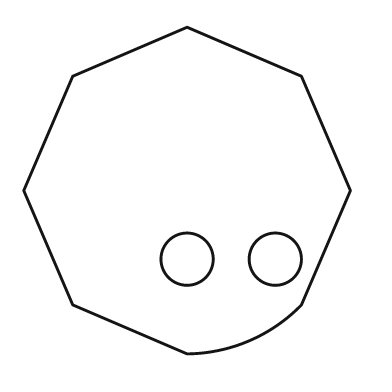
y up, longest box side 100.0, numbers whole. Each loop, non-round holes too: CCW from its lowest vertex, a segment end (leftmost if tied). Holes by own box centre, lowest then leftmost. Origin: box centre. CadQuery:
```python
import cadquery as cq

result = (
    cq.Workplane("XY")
    .moveTo(0.0, -50.0)
    .threePointArc((19.0, -46.0), (35.0, -35.0))
    .lineTo(50.0, 0.0)
    .lineTo(35.0, 35.0)
    .lineTo(0.0, 50.0)
    .lineTo(-35.0, 35.0)
    .lineTo(-50.0, 0.0)
    .lineTo(-35.0, -35.0)
    .close()
    .moveTo(0.0, -21.0)
    .circle(8.0)
    .moveTo(27.0, -21.0)
    .circle(8.0)
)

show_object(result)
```